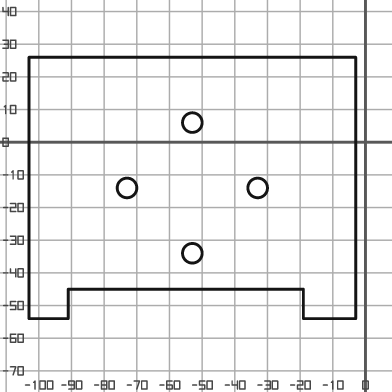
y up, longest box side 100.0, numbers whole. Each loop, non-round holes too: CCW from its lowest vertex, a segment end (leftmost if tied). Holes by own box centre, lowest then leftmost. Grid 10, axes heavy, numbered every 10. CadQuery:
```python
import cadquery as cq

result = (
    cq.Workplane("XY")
    .moveTo(-103.0, -54.0)
    .lineTo(-91.0, -54.0)
    .lineTo(-91.0, -45.0)
    .lineTo(-19.0, -45.0)
    .lineTo(-19.0, -54.0)
    .lineTo(-3.0, -54.0)
    .lineTo(-3.0, 26.0)
    .lineTo(-103.0, 26.0)
    .close()
    .moveTo(-53.0, -34.0)
    .circle(3.0)
    .moveTo(-73.0, -14.0)
    .circle(3.0)
    .moveTo(-33.0, -14.0)
    .circle(3.0)
    .moveTo(-53.0, 6.0)
    .circle(3.0)
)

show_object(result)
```